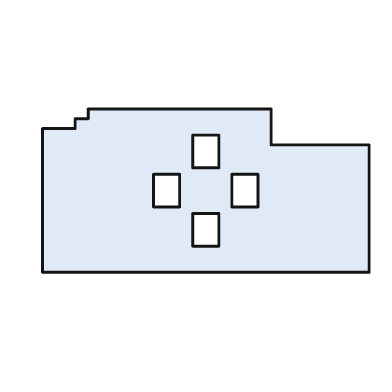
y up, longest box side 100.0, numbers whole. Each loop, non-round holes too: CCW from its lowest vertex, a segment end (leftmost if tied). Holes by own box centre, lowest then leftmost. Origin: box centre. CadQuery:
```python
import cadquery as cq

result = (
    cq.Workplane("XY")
    .moveTo(-50.0, -25.0)
    .lineTo(50.0, -25.0)
    .lineTo(50.0, 14.0)
    .lineTo(20.0, 14.0)
    .lineTo(20.0, 25.0)
    .lineTo(-36.0, 25.0)
    .lineTo(-36.0, 22.0)
    .lineTo(-40.0, 22.0)
    .lineTo(-40.0, 19.0)
    .lineTo(-50.0, 19.0)
    .close()
    .moveTo(-4.0, -17.0)
    .lineTo(4.0, -17.0)
    .lineTo(4.0, -7.0)
    .lineTo(-4.0, -7.0)
    .close()
    .moveTo(-16.0, -5.0)
    .lineTo(-8.0, -5.0)
    .lineTo(-8.0, 5.0)
    .lineTo(-16.0, 5.0)
    .close()
    .moveTo(8.0, -5.0)
    .lineTo(16.0, -5.0)
    .lineTo(16.0, 5.0)
    .lineTo(8.0, 5.0)
    .close()
    .moveTo(-4.0, 7.0)
    .lineTo(4.0, 7.0)
    .lineTo(4.0, 17.0)
    .lineTo(-4.0, 17.0)
    .close()
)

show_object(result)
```